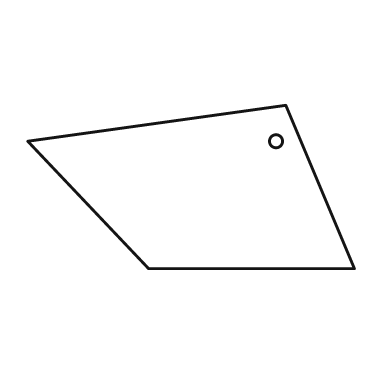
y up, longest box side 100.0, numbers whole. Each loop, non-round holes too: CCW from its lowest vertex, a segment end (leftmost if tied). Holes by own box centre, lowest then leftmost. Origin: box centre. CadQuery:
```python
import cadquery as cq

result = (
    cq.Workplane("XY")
    .moveTo(-13.0, -25.0)
    .lineTo(50.0, -25.0)
    .lineTo(29.0, 25.0)
    .lineTo(-50.0, 14.0)
    .close()
    .moveTo(26.0, 14.0)
    .circle(2.0)
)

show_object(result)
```